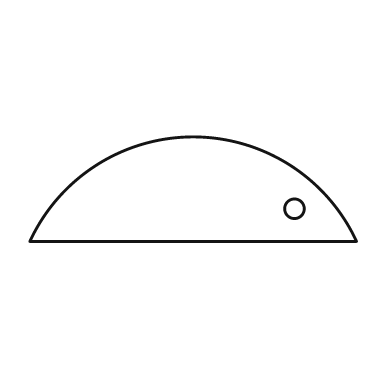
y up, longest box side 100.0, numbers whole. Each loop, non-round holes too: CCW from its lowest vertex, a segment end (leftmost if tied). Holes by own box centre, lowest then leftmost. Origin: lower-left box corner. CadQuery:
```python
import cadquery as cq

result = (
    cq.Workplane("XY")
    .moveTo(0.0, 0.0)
    .lineTo(100.0, 0.0)
    .threePointArc((50.0, 32.0), (0.0, 0.0))
    .close()
    .moveTo(81.0, 10.0)
    .circle(3.0)
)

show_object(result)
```